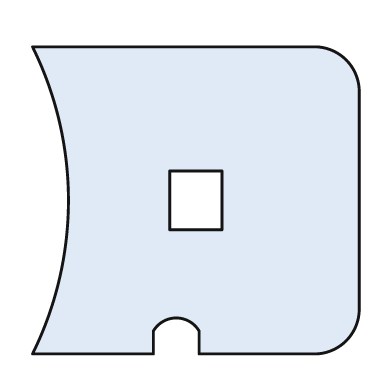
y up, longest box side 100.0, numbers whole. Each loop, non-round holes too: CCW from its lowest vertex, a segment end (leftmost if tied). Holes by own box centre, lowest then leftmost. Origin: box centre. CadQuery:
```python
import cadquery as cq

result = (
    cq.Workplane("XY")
    .moveTo(-50.0, -47.0)
    .lineTo(-13.0, -47.0)
    .lineTo(-13.0, -40.0)
    .threePointArc((-6.0, -36.0), (1.0, -40.0))
    .lineTo(1.0, -47.0)
    .lineTo(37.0, -47.0)
    .threePointArc((46.0, -43.0), (50.0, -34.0))
    .lineTo(50.0, 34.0)
    .threePointArc((46.0, 43.0), (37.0, 47.0))
    .lineTo(-50.0, 47.0)
    .threePointArc((-39.0, 0.0), (-50.0, -47.0))
    .close()
    .moveTo(-8.0, -9.0)
    .lineTo(8.0, -9.0)
    .lineTo(8.0, 9.0)
    .lineTo(-8.0, 9.0)
    .close()
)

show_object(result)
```